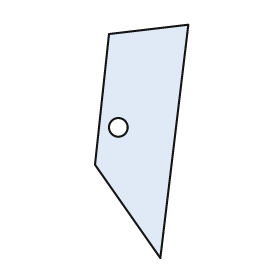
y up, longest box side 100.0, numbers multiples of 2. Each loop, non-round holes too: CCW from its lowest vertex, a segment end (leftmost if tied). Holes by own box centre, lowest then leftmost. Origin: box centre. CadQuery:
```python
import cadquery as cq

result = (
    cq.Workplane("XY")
    .moveTo(8.0, -50.0)
    .lineTo(20.0, 50.0)
    .lineTo(-14.0, 46.0)
    .lineTo(-20.0, -10.0)
    .close()
    .moveTo(-10.0, 6.0)
    .circle(4.0)
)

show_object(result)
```